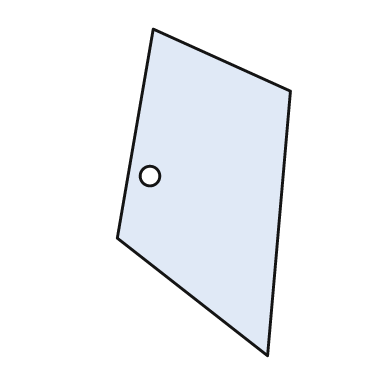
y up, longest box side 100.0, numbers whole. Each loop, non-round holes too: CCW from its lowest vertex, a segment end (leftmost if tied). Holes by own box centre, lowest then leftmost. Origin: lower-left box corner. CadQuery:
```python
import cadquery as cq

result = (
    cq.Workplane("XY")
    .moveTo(46.0, 0.0)
    .lineTo(53.0, 81.0)
    .lineTo(11.0, 100.0)
    .lineTo(0.0, 36.0)
    .close()
    .moveTo(10.0, 55.0)
    .circle(3.0)
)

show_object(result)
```